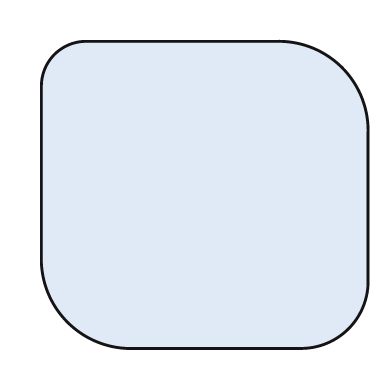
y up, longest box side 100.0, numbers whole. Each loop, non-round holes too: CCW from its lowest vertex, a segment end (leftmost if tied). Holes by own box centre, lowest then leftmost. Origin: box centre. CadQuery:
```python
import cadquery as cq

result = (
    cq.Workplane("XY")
    .moveTo(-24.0, -47.0)
    .lineTo(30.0, -47.0)
    .threePointArc((44.0, -41.0), (50.0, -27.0))
    .lineTo(50.0, 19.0)
    .threePointArc((42.0, 39.0), (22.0, 47.0))
    .lineTo(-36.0, 47.0)
    .threePointArc((-46.0, 43.0), (-50.0, 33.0))
    .lineTo(-50.0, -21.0)
    .threePointArc((-42.0, -39.0), (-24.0, -47.0))
    .close()
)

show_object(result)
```